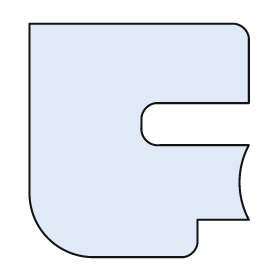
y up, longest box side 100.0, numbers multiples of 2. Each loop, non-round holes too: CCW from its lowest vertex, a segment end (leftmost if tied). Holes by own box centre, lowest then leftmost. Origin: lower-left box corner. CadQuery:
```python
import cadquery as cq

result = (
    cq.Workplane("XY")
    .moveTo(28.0, 0.0)
    .lineTo(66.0, 0.0)
    .threePointArc((70.0, 2.0), (72.0, 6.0))
    .lineTo(72.0, 16.0)
    .lineTo(94.0, 16.0)
    .threePointArc((90.0, 32.0), (94.0, 48.0))
    .lineTo(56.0, 48.0)
    .threePointArc((50.0, 50.0), (48.0, 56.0))
    .lineTo(48.0, 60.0)
    .threePointArc((50.0, 64.0), (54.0, 66.0))
    .lineTo(94.0, 66.0)
    .lineTo(94.0, 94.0)
    .threePointArc((92.0, 98.0), (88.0, 100.0))
    .lineTo(0.0, 100.0)
    .lineTo(0.0, 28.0)
    .threePointArc((8.0, 8.0), (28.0, 0.0))
    .close()
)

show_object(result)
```